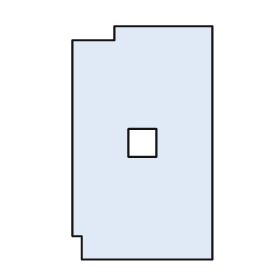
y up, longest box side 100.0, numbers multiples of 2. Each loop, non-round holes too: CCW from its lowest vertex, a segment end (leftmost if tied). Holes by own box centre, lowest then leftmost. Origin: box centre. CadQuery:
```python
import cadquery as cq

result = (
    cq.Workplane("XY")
    .moveTo(-26.0, -50.0)
    .lineTo(30.0, -50.0)
    .lineTo(30.0, 50.0)
    .lineTo(-12.0, 50.0)
    .lineTo(-12.0, 44.0)
    .lineTo(-30.0, 44.0)
    .lineTo(-30.0, -40.0)
    .lineTo(-26.0, -40.0)
    .close()
    .moveTo(-6.0, -6.0)
    .lineTo(6.0, -6.0)
    .lineTo(6.0, 6.0)
    .lineTo(-6.0, 6.0)
    .close()
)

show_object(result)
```